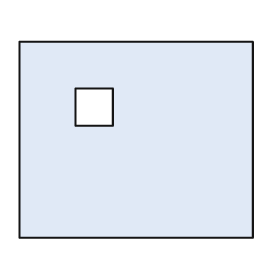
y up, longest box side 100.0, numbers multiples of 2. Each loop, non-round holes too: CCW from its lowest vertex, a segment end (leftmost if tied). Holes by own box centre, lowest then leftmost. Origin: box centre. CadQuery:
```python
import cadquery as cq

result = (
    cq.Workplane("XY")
    .moveTo(-50.0, -42.0)
    .lineTo(50.0, -42.0)
    .lineTo(50.0, 42.0)
    .lineTo(-50.0, 42.0)
    .close()
    .moveTo(-26.0, 6.0)
    .lineTo(-10.0, 6.0)
    .lineTo(-10.0, 22.0)
    .lineTo(-26.0, 22.0)
    .close()
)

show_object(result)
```